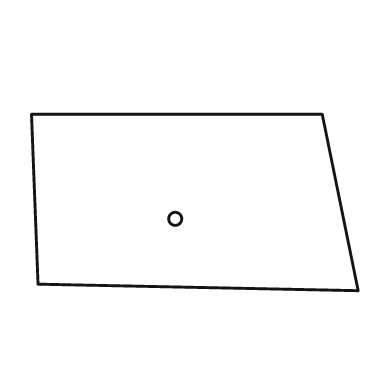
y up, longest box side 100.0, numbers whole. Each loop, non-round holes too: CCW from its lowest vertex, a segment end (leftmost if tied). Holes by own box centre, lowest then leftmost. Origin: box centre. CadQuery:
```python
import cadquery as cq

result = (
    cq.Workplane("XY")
    .moveTo(50.0, -27.0)
    .lineTo(39.0, 27.0)
    .lineTo(-50.0, 27.0)
    .lineTo(-48.0, -25.0)
    .close()
    .moveTo(-6.0, -5.0)
    .circle(2.0)
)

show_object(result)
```